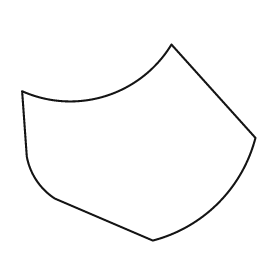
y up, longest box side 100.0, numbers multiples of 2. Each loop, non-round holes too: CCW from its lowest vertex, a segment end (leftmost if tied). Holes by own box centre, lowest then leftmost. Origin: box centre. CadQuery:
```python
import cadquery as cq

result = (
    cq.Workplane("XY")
    .moveTo(6.0, -42.0)
    .threePointArc((34.0, -26.0), (50.0, 2.0))
    .lineTo(14.0, 42.0)
    .threePointArc((-14.0, 20.0), (-50.0, 22.0))
    .lineTo(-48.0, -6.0)
    .threePointArc((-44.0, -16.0), (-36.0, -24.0))
    .close()
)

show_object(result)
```